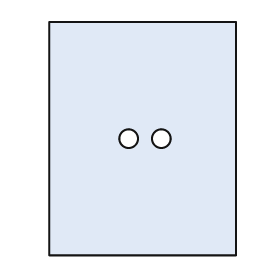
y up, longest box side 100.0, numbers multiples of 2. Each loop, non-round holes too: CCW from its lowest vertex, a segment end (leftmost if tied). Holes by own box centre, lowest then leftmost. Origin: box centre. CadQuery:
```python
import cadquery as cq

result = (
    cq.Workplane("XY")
    .moveTo(-40.0, -50.0)
    .lineTo(40.0, -50.0)
    .lineTo(40.0, 50.0)
    .lineTo(-40.0, 50.0)
    .close()
    .moveTo(-6.0, 0.0)
    .circle(4.0)
    .moveTo(8.0, 0.0)
    .circle(4.0)
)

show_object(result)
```